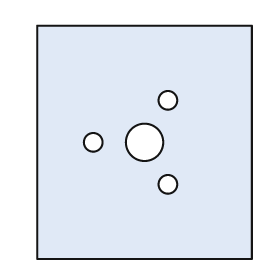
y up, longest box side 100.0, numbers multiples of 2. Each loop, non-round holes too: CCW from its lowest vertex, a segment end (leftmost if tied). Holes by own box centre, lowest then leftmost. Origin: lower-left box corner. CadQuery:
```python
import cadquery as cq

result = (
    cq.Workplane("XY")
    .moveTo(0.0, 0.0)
    .lineTo(92.0, 0.0)
    .lineTo(92.0, 100.0)
    .lineTo(0.0, 100.0)
    .close()
    .moveTo(56.0, 32.0)
    .circle(4.0)
    .moveTo(24.0, 50.0)
    .circle(4.0)
    .moveTo(46.0, 50.0)
    .circle(8.0)
    .moveTo(56.0, 68.0)
    .circle(4.0)
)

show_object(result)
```